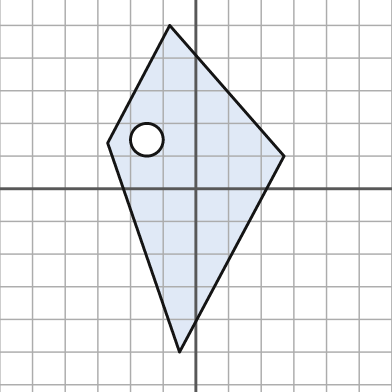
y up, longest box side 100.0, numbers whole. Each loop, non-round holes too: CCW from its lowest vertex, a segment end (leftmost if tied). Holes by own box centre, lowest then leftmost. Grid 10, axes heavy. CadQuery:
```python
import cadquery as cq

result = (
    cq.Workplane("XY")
    .moveTo(-5.0, -50.0)
    .lineTo(27.0, 10.0)
    .lineTo(-8.0, 50.0)
    .lineTo(-27.0, 14.0)
    .close()
    .moveTo(-15.0, 15.0)
    .circle(5.0)
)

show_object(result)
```